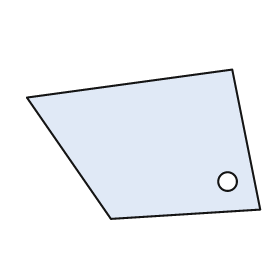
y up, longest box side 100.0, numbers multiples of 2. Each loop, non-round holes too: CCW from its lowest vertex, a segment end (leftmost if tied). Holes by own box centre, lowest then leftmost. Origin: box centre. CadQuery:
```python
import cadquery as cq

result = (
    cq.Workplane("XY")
    .moveTo(-14.0, -32.0)
    .lineTo(50.0, -28.0)
    .lineTo(38.0, 32.0)
    .lineTo(-50.0, 20.0)
    .close()
    .moveTo(36.0, -16.0)
    .circle(4.0)
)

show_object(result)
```